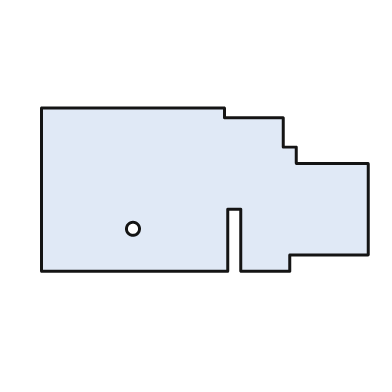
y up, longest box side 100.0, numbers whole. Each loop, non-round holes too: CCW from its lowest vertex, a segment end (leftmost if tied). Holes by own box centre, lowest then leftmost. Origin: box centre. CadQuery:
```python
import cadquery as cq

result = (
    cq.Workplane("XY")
    .moveTo(-50.0, -25.0)
    .lineTo(7.0, -25.0)
    .lineTo(7.0, -6.0)
    .lineTo(11.0, -6.0)
    .lineTo(11.0, -25.0)
    .lineTo(26.0, -25.0)
    .lineTo(26.0, -20.0)
    .lineTo(50.0, -20.0)
    .lineTo(50.0, 8.0)
    .lineTo(28.0, 8.0)
    .lineTo(28.0, 13.0)
    .lineTo(24.0, 13.0)
    .lineTo(24.0, 22.0)
    .lineTo(6.0, 22.0)
    .lineTo(6.0, 25.0)
    .lineTo(-50.0, 25.0)
    .close()
    .moveTo(-22.0, -12.0)
    .circle(2.0)
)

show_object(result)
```